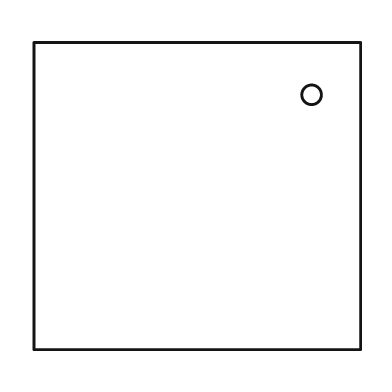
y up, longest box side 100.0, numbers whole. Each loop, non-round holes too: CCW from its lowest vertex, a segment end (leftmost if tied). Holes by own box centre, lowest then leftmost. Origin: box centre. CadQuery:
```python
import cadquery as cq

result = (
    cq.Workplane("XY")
    .moveTo(-50.0, -47.0)
    .lineTo(50.0, -47.0)
    .lineTo(50.0, 47.0)
    .lineTo(-50.0, 47.0)
    .close()
    .moveTo(35.0, 31.0)
    .circle(3.0)
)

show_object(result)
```